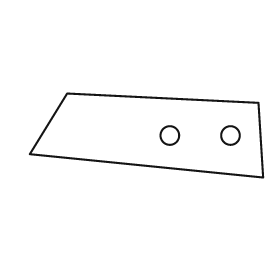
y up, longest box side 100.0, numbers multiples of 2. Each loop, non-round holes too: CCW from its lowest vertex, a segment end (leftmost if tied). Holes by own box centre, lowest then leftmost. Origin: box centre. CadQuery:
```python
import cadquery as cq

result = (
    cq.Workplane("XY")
    .moveTo(50.0, -18.0)
    .lineTo(48.0, 14.0)
    .lineTo(-34.0, 18.0)
    .lineTo(-50.0, -8.0)
    .close()
    .moveTo(10.0, 0.0)
    .circle(4.0)
    .moveTo(36.0, 0.0)
    .circle(4.0)
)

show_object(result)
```